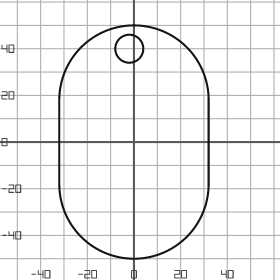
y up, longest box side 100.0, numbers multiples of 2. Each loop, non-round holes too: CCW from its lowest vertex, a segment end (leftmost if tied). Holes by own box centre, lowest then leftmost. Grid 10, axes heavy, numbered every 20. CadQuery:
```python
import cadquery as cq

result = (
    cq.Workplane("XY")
    .moveTo(-32.0, -18.0)
    .threePointArc((0.0, -50.0), (32.0, -18.0))
    .lineTo(32.0, 18.0)
    .threePointArc((0.0, 50.0), (-32.0, 18.0))
    .close()
    .moveTo(-2.0, 40.0)
    .circle(6.0)
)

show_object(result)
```